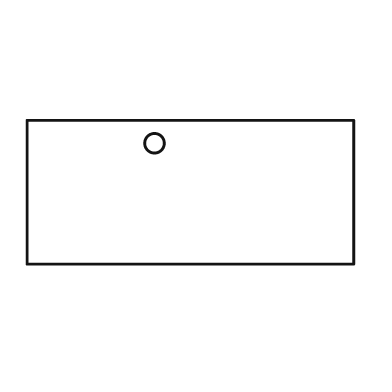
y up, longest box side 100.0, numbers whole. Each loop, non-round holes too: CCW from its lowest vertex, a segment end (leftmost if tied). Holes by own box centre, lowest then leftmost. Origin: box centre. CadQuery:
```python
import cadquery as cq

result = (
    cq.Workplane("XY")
    .moveTo(-50.0, -22.0)
    .lineTo(50.0, -22.0)
    .lineTo(50.0, 22.0)
    .lineTo(-50.0, 22.0)
    .close()
    .moveTo(-11.0, 15.0)
    .circle(3.0)
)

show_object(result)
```